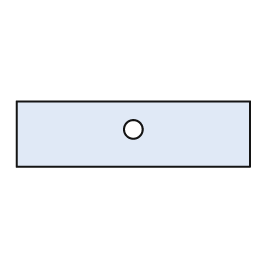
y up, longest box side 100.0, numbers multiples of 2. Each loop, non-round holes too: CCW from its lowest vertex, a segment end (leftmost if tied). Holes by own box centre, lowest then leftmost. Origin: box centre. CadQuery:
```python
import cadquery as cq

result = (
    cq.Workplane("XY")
    .moveTo(-50.0, -14.0)
    .lineTo(50.0, -14.0)
    .lineTo(50.0, 14.0)
    .lineTo(-50.0, 14.0)
    .close()
    .moveTo(0.0, 2.0)
    .circle(4.0)
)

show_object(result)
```